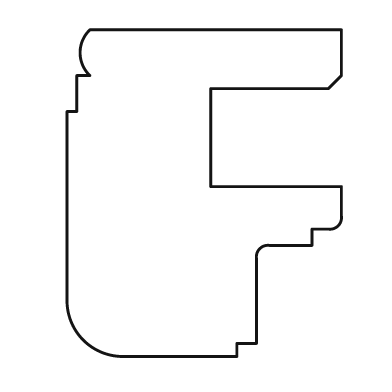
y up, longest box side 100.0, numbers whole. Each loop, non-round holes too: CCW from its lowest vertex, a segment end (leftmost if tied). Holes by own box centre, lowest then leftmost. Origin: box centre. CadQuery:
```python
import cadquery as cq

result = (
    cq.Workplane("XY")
    .moveTo(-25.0, -50.0)
    .lineTo(10.0, -50.0)
    .lineTo(10.0, -46.0)
    .lineTo(16.0, -46.0)
    .lineTo(16.0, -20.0)
    .threePointArc((17.0, -17.0), (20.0, -16.0))
    .lineTo(33.0, -16.0)
    .lineTo(33.0, -11.0)
    .lineTo(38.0, -11.0)
    .threePointArc((41.0, -10.0), (42.0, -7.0))
    .lineTo(42.0, 2.0)
    .lineTo(2.0, 2.0)
    .lineTo(2.0, 32.0)
    .lineTo(38.0, 32.0)
    .lineTo(42.0, 36.0)
    .lineTo(42.0, 50.0)
    .lineTo(-35.0, 50.0)
    .threePointArc((-38.0, 43.0), (-35.0, 36.0))
    .lineTo(-39.0, 36.0)
    .lineTo(-39.0, 25.0)
    .lineTo(-42.0, 25.0)
    .lineTo(-42.0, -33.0)
    .threePointArc((-37.0, -45.0), (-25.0, -50.0))
    .close()
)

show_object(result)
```